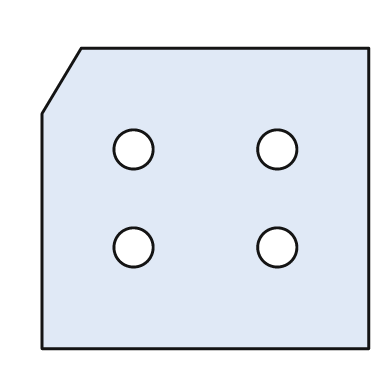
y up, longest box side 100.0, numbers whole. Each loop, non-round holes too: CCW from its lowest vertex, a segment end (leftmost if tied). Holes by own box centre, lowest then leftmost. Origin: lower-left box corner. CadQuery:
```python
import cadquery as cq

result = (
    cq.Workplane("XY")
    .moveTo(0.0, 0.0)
    .lineTo(100.0, 0.0)
    .lineTo(100.0, 92.0)
    .lineTo(12.0, 92.0)
    .lineTo(0.0, 72.0)
    .close()
    .moveTo(28.0, 31.0)
    .circle(6.0)
    .moveTo(72.0, 31.0)
    .circle(6.0)
    .moveTo(28.0, 61.0)
    .circle(6.0)
    .moveTo(72.0, 61.0)
    .circle(6.0)
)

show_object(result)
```